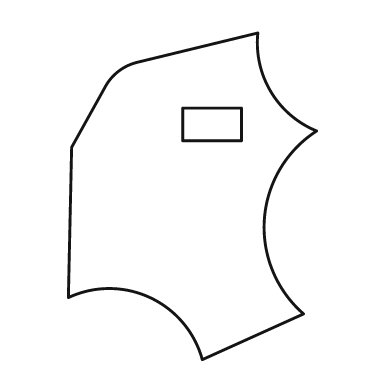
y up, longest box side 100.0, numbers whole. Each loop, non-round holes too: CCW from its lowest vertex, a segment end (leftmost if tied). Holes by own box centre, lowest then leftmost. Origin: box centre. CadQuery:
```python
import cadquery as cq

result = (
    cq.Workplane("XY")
    .moveTo(3.0, -50.0)
    .lineTo(34.0, -36.0)
    .threePointArc((22.0, -7.0), (38.0, 20.0))
    .threePointArc((24.0, 32.0), (20.0, 50.0))
    .lineTo(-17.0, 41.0)
    .threePointArc((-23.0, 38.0), (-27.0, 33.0))
    .lineTo(-37.0, 15.0)
    .lineTo(-38.0, -31.0)
    .threePointArc((-13.0, -31.0), (3.0, -50.0))
    .close()
    .moveTo(-3.0, 17.0)
    .lineTo(15.0, 17.0)
    .lineTo(15.0, 27.0)
    .lineTo(-3.0, 27.0)
    .close()
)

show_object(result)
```